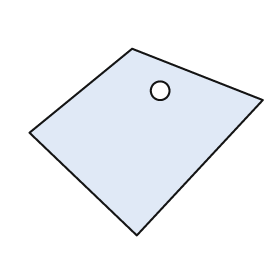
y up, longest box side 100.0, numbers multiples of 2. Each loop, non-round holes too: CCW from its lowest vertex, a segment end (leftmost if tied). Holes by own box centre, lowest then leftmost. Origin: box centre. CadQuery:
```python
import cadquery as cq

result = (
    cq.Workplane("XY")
    .moveTo(-4.0, -40.0)
    .lineTo(50.0, 18.0)
    .lineTo(-6.0, 40.0)
    .lineTo(-50.0, 4.0)
    .close()
    .moveTo(6.0, 22.0)
    .circle(4.0)
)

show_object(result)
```